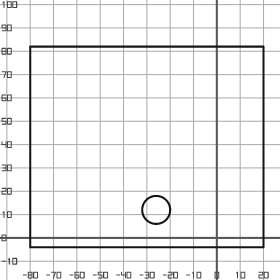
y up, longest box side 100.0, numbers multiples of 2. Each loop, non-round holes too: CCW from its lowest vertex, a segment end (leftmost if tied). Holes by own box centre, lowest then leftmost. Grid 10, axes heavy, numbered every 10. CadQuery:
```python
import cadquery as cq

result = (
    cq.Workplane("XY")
    .moveTo(-80.0, -4.0)
    .lineTo(20.0, -4.0)
    .lineTo(20.0, 82.0)
    .lineTo(-80.0, 82.0)
    .close()
    .moveTo(-26.0, 12.0)
    .circle(6.0)
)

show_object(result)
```